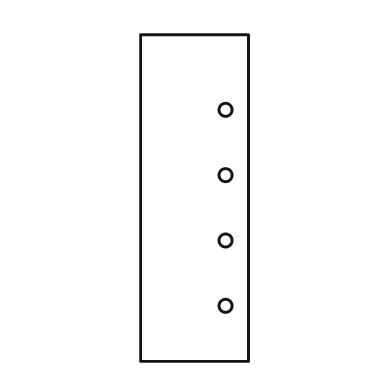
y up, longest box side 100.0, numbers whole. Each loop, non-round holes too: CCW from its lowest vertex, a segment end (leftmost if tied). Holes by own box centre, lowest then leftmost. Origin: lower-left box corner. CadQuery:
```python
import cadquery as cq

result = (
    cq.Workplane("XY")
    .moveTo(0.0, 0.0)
    .lineTo(33.0, 0.0)
    .lineTo(33.0, 100.0)
    .lineTo(0.0, 100.0)
    .close()
    .moveTo(26.0, 17.0)
    .circle(2.0)
    .moveTo(26.0, 37.0)
    .circle(2.0)
    .moveTo(26.0, 57.0)
    .circle(2.0)
    .moveTo(26.0, 77.0)
    .circle(2.0)
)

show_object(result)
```